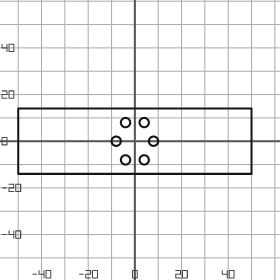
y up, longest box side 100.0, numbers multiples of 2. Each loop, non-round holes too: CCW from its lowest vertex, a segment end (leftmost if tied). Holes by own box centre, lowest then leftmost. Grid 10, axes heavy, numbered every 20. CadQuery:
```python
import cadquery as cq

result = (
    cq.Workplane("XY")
    .moveTo(-50.0, -14.0)
    .lineTo(50.0, -14.0)
    .lineTo(50.0, 14.0)
    .lineTo(-50.0, 14.0)
    .close()
    .moveTo(-4.0, -8.0)
    .circle(2.0)
    .moveTo(4.0, -8.0)
    .circle(2.0)
    .moveTo(-8.0, 0.0)
    .circle(2.0)
    .moveTo(8.0, 0.0)
    .circle(2.0)
    .moveTo(-4.0, 8.0)
    .circle(2.0)
    .moveTo(4.0, 8.0)
    .circle(2.0)
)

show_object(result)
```